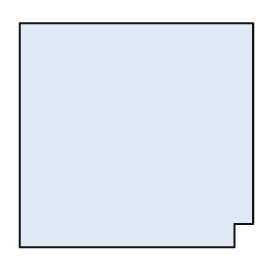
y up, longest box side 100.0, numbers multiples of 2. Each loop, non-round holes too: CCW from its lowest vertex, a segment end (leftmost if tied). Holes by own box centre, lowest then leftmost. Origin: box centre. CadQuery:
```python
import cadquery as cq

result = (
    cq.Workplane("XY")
    .moveTo(-50.0, -48.0)
    .lineTo(42.0, -48.0)
    .lineTo(42.0, -38.0)
    .lineTo(50.0, -38.0)
    .lineTo(50.0, 48.0)
    .lineTo(-50.0, 48.0)
    .close()
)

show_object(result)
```